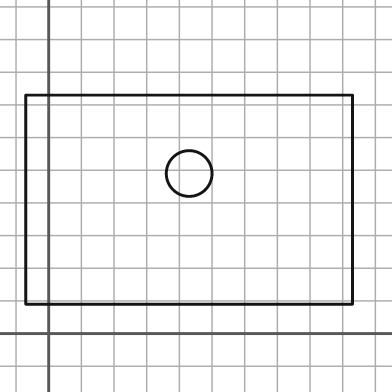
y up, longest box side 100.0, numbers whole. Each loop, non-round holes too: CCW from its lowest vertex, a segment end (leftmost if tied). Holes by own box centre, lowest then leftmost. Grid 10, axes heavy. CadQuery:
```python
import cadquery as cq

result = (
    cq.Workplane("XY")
    .moveTo(-7.0, 9.0)
    .lineTo(93.0, 9.0)
    .lineTo(93.0, 73.0)
    .lineTo(-7.0, 73.0)
    .close()
    .moveTo(43.0, 49.0)
    .circle(7.0)
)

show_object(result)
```